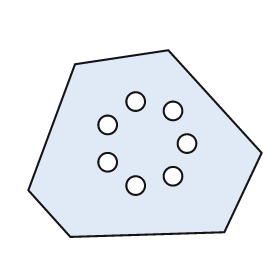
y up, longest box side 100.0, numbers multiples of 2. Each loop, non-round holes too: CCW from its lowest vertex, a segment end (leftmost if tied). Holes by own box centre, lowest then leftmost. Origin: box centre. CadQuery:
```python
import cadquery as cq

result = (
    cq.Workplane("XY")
    .moveTo(-32.0, -40.0)
    .lineTo(34.0, -38.0)
    .lineTo(50.0, -4.0)
    .lineTo(10.0, 40.0)
    .lineTo(-30.0, 34.0)
    .lineTo(-50.0, -20.0)
    .close()
    .moveTo(-4.0, -18.0)
    .circle(4.0)
    .moveTo(12.0, -14.0)
    .circle(4.0)
    .moveTo(-16.0, -8.0)
    .circle(4.0)
    .moveTo(18.0, 0.0)
    .circle(4.0)
    .moveTo(-16.0, 8.0)
    .circle(4.0)
    .moveTo(12.0, 14.0)
    .circle(4.0)
    .moveTo(-4.0, 18.0)
    .circle(4.0)
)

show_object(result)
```